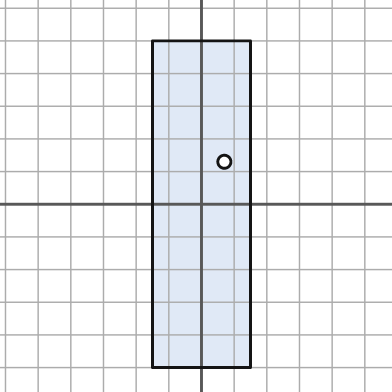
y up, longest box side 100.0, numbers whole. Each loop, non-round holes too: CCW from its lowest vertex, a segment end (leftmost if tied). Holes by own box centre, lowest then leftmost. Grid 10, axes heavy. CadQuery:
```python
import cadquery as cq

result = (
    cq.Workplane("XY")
    .moveTo(-15.0, -50.0)
    .lineTo(15.0, -50.0)
    .lineTo(15.0, 50.0)
    .lineTo(-15.0, 50.0)
    .close()
    .moveTo(7.0, 13.0)
    .circle(2.0)
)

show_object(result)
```